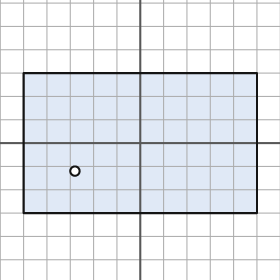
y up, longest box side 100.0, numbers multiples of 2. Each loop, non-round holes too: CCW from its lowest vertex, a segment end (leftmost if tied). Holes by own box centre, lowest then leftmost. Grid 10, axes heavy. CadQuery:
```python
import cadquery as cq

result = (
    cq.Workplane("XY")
    .moveTo(-50.0, -30.0)
    .lineTo(50.0, -30.0)
    .lineTo(50.0, 30.0)
    .lineTo(-50.0, 30.0)
    .close()
    .moveTo(-28.0, -12.0)
    .circle(2.0)
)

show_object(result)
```